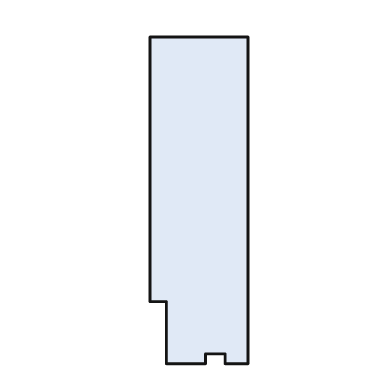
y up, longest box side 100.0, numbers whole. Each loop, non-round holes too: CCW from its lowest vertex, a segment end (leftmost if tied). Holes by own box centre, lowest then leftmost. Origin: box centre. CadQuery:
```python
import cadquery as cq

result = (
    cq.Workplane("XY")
    .moveTo(-10.0, -50.0)
    .lineTo(2.0, -50.0)
    .lineTo(2.0, -47.0)
    .lineTo(8.0, -47.0)
    .lineTo(8.0, -50.0)
    .lineTo(15.0, -50.0)
    .lineTo(15.0, 50.0)
    .lineTo(-15.0, 50.0)
    .lineTo(-15.0, -31.0)
    .lineTo(-10.0, -31.0)
    .close()
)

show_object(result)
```